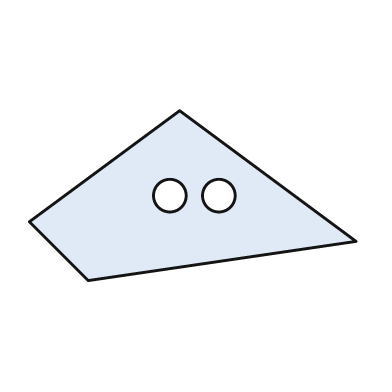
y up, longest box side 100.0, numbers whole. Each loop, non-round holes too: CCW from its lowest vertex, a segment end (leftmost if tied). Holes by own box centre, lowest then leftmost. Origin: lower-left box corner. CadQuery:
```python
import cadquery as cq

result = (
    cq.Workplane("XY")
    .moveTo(18.0, 0.0)
    .lineTo(100.0, 12.0)
    .lineTo(46.0, 52.0)
    .lineTo(0.0, 18.0)
    .close()
    .moveTo(43.0, 26.0)
    .circle(5.0)
    .moveTo(58.0, 26.0)
    .circle(5.0)
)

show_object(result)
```